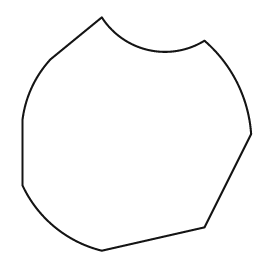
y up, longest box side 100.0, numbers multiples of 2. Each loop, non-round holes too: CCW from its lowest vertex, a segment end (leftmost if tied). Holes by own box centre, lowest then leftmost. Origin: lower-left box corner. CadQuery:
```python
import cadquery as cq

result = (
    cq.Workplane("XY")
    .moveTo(34.0, 0.0)
    .lineTo(78.0, 10.0)
    .lineTo(98.0, 50.0)
    .threePointArc((92.0, 72.0), (78.0, 90.0))
    .threePointArc((54.0, 86.0), (34.0, 100.0))
    .lineTo(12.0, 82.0)
    .threePointArc((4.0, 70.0), (0.0, 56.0))
    .lineTo(0.0, 28.0)
    .threePointArc((14.0, 10.0), (34.0, 0.0))
    .close()
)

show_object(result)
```